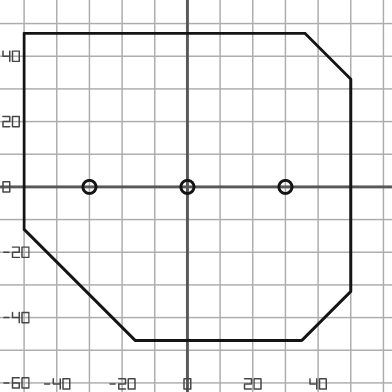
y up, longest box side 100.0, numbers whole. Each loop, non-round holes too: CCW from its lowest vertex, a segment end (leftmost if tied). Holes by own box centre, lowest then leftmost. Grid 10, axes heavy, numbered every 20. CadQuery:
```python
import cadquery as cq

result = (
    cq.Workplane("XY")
    .moveTo(-16.0, -47.0)
    .lineTo(35.0, -47.0)
    .lineTo(50.0, -32.0)
    .lineTo(50.0, 33.0)
    .lineTo(36.0, 47.0)
    .lineTo(-50.0, 47.0)
    .lineTo(-50.0, -13.0)
    .close()
    .moveTo(-30.0, 0.0)
    .circle(2.0)
    .moveTo(0.0, 0.0)
    .circle(2.0)
    .moveTo(30.0, 0.0)
    .circle(2.0)
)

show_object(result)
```